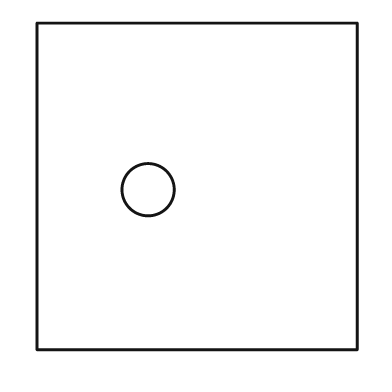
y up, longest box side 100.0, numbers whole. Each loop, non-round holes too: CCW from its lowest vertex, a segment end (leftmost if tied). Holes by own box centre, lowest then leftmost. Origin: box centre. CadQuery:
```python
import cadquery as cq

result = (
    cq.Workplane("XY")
    .moveTo(-49.0, -50.0)
    .lineTo(49.0, -50.0)
    .lineTo(49.0, 50.0)
    .lineTo(-49.0, 50.0)
    .close()
    .moveTo(-15.0, -1.0)
    .circle(8.0)
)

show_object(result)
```